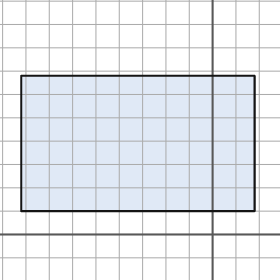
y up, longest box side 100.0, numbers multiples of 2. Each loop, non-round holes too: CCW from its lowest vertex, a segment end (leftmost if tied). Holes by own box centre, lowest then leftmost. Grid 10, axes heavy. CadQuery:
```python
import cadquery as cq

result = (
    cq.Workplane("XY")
    .moveTo(-82.0, 10.0)
    .lineTo(18.0, 10.0)
    .lineTo(18.0, 68.0)
    .lineTo(-82.0, 68.0)
    .close()
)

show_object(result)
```